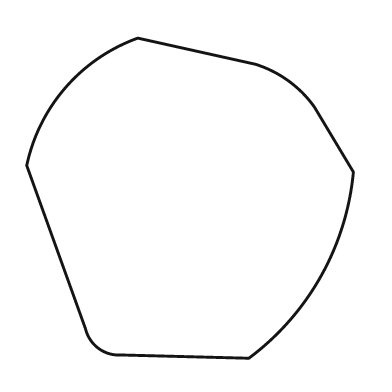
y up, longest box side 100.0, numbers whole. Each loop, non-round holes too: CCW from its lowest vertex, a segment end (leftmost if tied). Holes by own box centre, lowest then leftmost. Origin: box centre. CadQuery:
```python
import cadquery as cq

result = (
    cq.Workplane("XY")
    .moveTo(18.0, -49.0)
    .threePointArc((40.0, -24.0), (50.0, 8.0))
    .lineTo(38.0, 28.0)
    .threePointArc((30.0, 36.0), (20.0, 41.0))
    .lineTo(-16.0, 49.0)
    .threePointArc((-38.0, 34.0), (-50.0, 10.0))
    .lineTo(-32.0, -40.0)
    .threePointArc((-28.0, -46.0), (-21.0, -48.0))
    .close()
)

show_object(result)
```